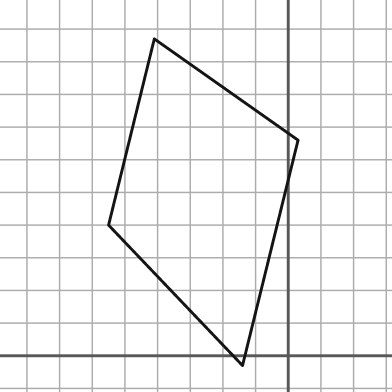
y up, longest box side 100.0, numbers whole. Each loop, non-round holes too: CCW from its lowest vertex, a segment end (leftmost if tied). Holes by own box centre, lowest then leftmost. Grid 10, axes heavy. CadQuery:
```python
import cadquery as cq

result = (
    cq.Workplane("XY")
    .moveTo(-14.0, -3.0)
    .lineTo(3.0, 66.0)
    .lineTo(-41.0, 97.0)
    .lineTo(-55.0, 40.0)
    .close()
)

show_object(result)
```